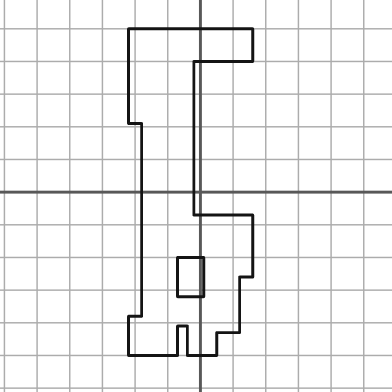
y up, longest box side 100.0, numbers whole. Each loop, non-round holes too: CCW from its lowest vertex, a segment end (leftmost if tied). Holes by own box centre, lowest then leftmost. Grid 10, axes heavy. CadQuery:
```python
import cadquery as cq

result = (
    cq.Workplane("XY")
    .moveTo(-22.0, -50.0)
    .lineTo(-7.0, -50.0)
    .lineTo(-7.0, -41.0)
    .lineTo(-4.0, -41.0)
    .lineTo(-4.0, -50.0)
    .lineTo(5.0, -50.0)
    .lineTo(5.0, -43.0)
    .lineTo(12.0, -43.0)
    .lineTo(12.0, -26.0)
    .lineTo(16.0, -26.0)
    .lineTo(16.0, -7.0)
    .lineTo(-2.0, -7.0)
    .lineTo(-2.0, 40.0)
    .lineTo(16.0, 40.0)
    .lineTo(16.0, 50.0)
    .lineTo(-22.0, 50.0)
    .lineTo(-22.0, 21.0)
    .lineTo(-18.0, 21.0)
    .lineTo(-18.0, -38.0)
    .lineTo(-22.0, -38.0)
    .close()
    .moveTo(-7.0, -32.0)
    .lineTo(1.0, -32.0)
    .lineTo(1.0, -20.0)
    .lineTo(-7.0, -20.0)
    .close()
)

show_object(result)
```